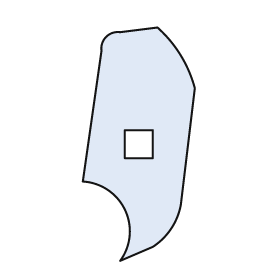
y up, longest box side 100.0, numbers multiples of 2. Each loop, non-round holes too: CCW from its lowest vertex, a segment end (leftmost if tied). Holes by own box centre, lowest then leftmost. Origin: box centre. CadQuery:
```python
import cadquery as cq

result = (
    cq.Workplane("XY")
    .moveTo(-8.0, -50.0)
    .lineTo(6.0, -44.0)
    .threePointArc((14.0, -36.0), (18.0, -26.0))
    .lineTo(24.0, 24.0)
    .threePointArc((18.0, 38.0), (8.0, 50.0))
    .lineTo(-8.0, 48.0)
    .threePointArc((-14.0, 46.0), (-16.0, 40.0))
    .lineTo(-24.0, -16.0)
    .threePointArc((-6.0, -28.0), (-8.0, -50.0))
    .close()
    .moveTo(-6.0, -6.0)
    .lineTo(6.0, -6.0)
    .lineTo(6.0, 6.0)
    .lineTo(-6.0, 6.0)
    .close()
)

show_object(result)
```